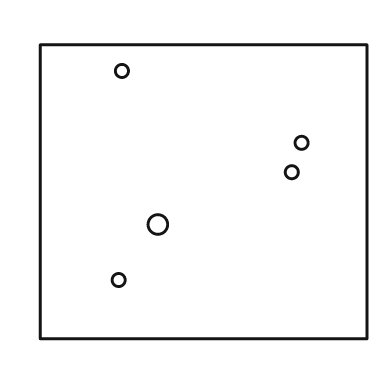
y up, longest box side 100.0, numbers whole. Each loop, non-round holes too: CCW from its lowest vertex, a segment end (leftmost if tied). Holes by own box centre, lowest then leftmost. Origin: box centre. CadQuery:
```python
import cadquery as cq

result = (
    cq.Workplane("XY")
    .moveTo(-50.0, -45.0)
    .lineTo(50.0, -45.0)
    .lineTo(50.0, 45.0)
    .lineTo(-50.0, 45.0)
    .close()
    .moveTo(-26.0, -27.0)
    .circle(2.0)
    .moveTo(-14.0, -10.0)
    .circle(3.0)
    .moveTo(27.0, 6.0)
    .circle(2.0)
    .moveTo(30.0, 15.0)
    .circle(2.0)
    .moveTo(-25.0, 37.0)
    .circle(2.0)
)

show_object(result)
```